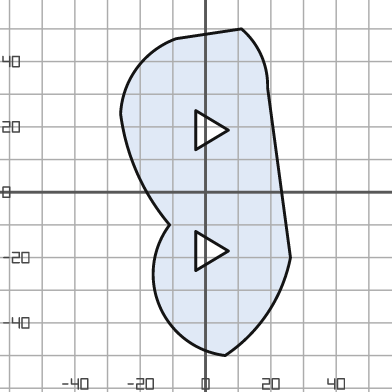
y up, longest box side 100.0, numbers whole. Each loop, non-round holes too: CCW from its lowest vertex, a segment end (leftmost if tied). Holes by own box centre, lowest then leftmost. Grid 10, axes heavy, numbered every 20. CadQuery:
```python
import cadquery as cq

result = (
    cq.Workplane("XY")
    .moveTo(6.0, -50.0)
    .threePointArc((19.0, -37.0), (26.0, -20.0))
    .lineTo(19.0, 32.0)
    .threePointArc((17.0, 42.0), (11.0, 50.0))
    .lineTo(-9.0, 47.0)
    .threePointArc((-21.0, 38.0), (-26.0, 24.0))
    .threePointArc((-21.0, 6.0), (-11.0, -10.0))
    .threePointArc((-14.0, -35.0), (6.0, -50.0))
    .close()
    .moveTo(-3.0, -24.0)
    .lineTo(7.0, -18.0)
    .lineTo(-3.0, -12.0)
    .close()
    .moveTo(-3.0, 13.0)
    .lineTo(7.0, 19.0)
    .lineTo(-3.0, 25.0)
    .close()
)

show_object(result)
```